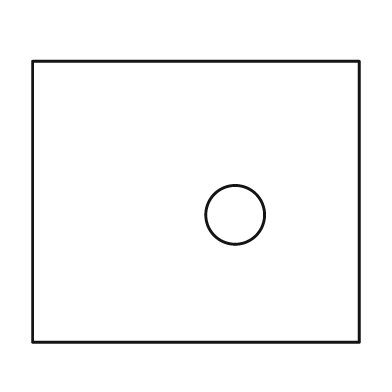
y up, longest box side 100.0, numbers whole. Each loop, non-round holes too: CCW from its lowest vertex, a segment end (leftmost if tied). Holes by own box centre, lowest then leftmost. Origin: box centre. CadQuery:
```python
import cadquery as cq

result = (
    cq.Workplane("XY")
    .moveTo(-50.0, -43.0)
    .lineTo(50.0, -43.0)
    .lineTo(50.0, 43.0)
    .lineTo(-50.0, 43.0)
    .close()
    .moveTo(12.0, -4.0)
    .circle(9.0)
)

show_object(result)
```